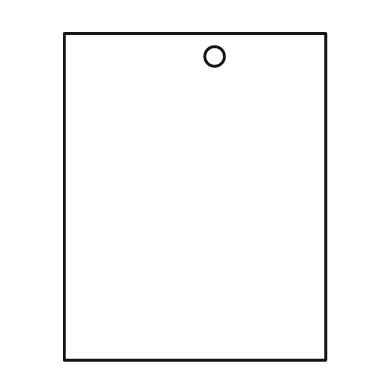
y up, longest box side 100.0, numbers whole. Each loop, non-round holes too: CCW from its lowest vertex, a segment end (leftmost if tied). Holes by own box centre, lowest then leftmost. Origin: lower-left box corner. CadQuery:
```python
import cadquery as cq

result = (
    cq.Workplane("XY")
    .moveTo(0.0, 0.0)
    .lineTo(80.0, 0.0)
    .lineTo(80.0, 100.0)
    .lineTo(0.0, 100.0)
    .close()
    .moveTo(46.0, 93.0)
    .circle(3.0)
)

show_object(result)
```